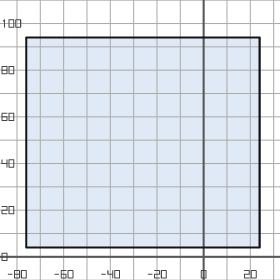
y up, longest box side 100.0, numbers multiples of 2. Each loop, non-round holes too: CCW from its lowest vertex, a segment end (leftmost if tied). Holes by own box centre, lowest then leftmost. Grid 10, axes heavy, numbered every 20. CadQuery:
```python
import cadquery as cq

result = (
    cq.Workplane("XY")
    .moveTo(-76.0, 4.0)
    .lineTo(24.0, 4.0)
    .lineTo(24.0, 94.0)
    .lineTo(-76.0, 94.0)
    .close()
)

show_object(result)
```